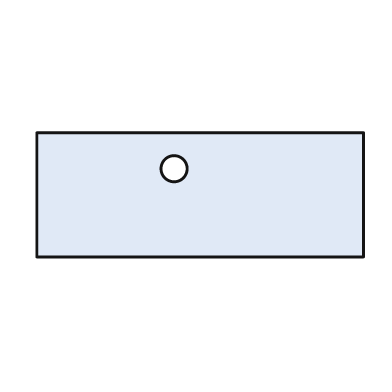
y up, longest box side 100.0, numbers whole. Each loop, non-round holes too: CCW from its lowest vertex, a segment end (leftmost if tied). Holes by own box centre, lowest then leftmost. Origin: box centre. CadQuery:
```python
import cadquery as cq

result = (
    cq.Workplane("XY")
    .moveTo(-50.0, -19.0)
    .lineTo(50.0, -19.0)
    .lineTo(50.0, 19.0)
    .lineTo(-50.0, 19.0)
    .close()
    .moveTo(-8.0, 8.0)
    .circle(4.0)
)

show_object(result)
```